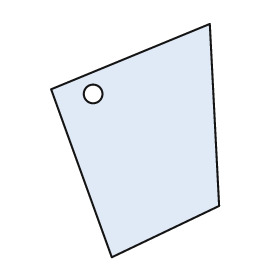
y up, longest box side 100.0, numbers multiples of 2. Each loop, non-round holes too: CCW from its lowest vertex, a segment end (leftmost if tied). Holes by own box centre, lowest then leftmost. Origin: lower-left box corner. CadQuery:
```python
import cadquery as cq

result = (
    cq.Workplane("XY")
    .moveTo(26.0, 0.0)
    .lineTo(72.0, 22.0)
    .lineTo(68.0, 100.0)
    .lineTo(0.0, 72.0)
    .close()
    .moveTo(18.0, 70.0)
    .circle(4.0)
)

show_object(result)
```